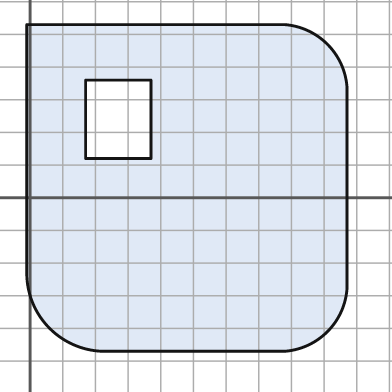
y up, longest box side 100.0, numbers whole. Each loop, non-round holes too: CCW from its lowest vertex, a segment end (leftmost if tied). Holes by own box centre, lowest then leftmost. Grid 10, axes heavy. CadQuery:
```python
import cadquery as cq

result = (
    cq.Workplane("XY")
    .moveTo(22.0, -47.0)
    .lineTo(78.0, -47.0)
    .threePointArc((91.0, -41.0), (97.0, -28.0))
    .lineTo(97.0, 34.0)
    .threePointArc((91.0, 47.0), (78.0, 53.0))
    .lineTo(-1.0, 53.0)
    .lineTo(-1.0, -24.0)
    .threePointArc((6.0, -40.0), (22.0, -47.0))
    .close()
    .moveTo(17.0, 12.0)
    .lineTo(37.0, 12.0)
    .lineTo(37.0, 36.0)
    .lineTo(17.0, 36.0)
    .close()
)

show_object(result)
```